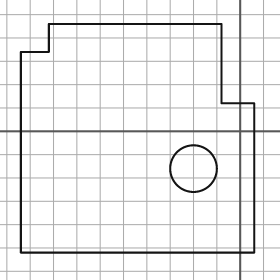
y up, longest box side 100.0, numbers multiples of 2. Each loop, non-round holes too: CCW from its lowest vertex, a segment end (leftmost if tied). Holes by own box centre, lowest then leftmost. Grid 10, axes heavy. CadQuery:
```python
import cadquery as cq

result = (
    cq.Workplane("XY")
    .moveTo(-94.0, -52.0)
    .lineTo(6.0, -52.0)
    .lineTo(6.0, 12.0)
    .lineTo(-8.0, 12.0)
    .lineTo(-8.0, 46.0)
    .lineTo(-82.0, 46.0)
    .lineTo(-82.0, 34.0)
    .lineTo(-94.0, 34.0)
    .close()
    .moveTo(-20.0, -16.0)
    .circle(10.0)
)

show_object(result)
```